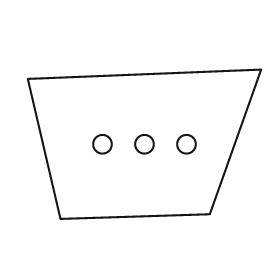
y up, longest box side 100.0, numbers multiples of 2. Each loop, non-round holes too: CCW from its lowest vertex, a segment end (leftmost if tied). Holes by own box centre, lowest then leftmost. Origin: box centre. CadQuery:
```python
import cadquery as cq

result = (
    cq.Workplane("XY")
    .moveTo(-36.0, -32.0)
    .lineTo(28.0, -30.0)
    .lineTo(50.0, 32.0)
    .lineTo(-50.0, 28.0)
    .close()
    .moveTo(-18.0, 0.0)
    .circle(4.0)
    .moveTo(0.0, 0.0)
    .circle(4.0)
    .moveTo(18.0, 0.0)
    .circle(4.0)
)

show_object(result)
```